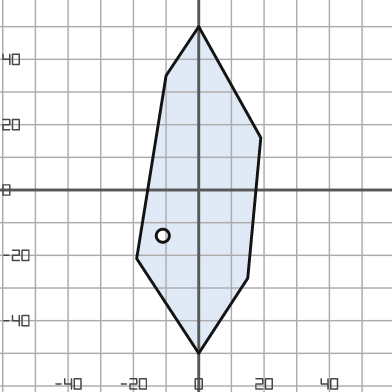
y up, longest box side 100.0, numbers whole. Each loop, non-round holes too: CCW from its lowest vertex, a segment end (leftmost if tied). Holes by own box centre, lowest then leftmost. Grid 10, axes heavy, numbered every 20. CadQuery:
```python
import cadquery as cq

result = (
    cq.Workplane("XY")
    .moveTo(0.0, -50.0)
    .lineTo(15.0, -27.0)
    .lineTo(19.0, 16.0)
    .lineTo(0.0, 50.0)
    .lineTo(-10.0, 35.0)
    .lineTo(-19.0, -21.0)
    .close()
    .moveTo(-11.0, -14.0)
    .circle(2.0)
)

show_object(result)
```